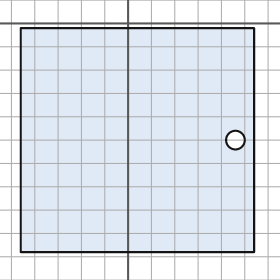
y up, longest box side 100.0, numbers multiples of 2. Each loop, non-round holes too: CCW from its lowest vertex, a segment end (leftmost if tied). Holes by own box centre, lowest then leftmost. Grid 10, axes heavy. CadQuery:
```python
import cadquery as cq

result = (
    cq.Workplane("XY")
    .moveTo(-46.0, -98.0)
    .lineTo(54.0, -98.0)
    .lineTo(54.0, -2.0)
    .lineTo(-46.0, -2.0)
    .close()
    .moveTo(46.0, -50.0)
    .circle(4.0)
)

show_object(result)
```